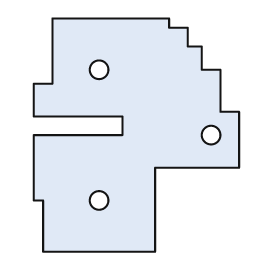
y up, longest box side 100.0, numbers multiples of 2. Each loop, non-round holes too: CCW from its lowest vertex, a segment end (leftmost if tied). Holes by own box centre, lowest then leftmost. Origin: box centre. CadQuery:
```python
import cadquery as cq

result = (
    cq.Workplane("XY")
    .moveTo(-40.0, -50.0)
    .lineTo(8.0, -50.0)
    .lineTo(8.0, -14.0)
    .lineTo(44.0, -14.0)
    .lineTo(44.0, 10.0)
    .lineTo(36.0, 10.0)
    .lineTo(36.0, 28.0)
    .lineTo(28.0, 28.0)
    .lineTo(28.0, 38.0)
    .lineTo(22.0, 38.0)
    .lineTo(22.0, 46.0)
    .lineTo(14.0, 46.0)
    .lineTo(14.0, 50.0)
    .lineTo(-36.0, 50.0)
    .lineTo(-36.0, 22.0)
    .lineTo(-44.0, 22.0)
    .lineTo(-44.0, 8.0)
    .lineTo(-6.0, 8.0)
    .lineTo(-6.0, 0.0)
    .lineTo(-44.0, 0.0)
    .lineTo(-44.0, -28.0)
    .lineTo(-40.0, -28.0)
    .close()
    .moveTo(-16.0, -28.0)
    .circle(4.0)
    .moveTo(32.0, 0.0)
    .circle(4.0)
    .moveTo(-16.0, 28.0)
    .circle(4.0)
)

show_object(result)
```